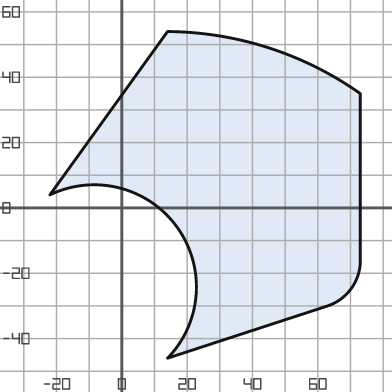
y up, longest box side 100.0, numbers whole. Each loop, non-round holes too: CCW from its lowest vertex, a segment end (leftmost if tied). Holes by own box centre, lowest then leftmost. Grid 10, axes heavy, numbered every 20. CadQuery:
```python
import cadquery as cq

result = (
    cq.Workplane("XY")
    .moveTo(14.0, -46.0)
    .lineTo(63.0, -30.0)
    .threePointArc((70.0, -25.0), (73.0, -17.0))
    .lineTo(73.0, 35.0)
    .threePointArc((45.0, 49.0), (14.0, 54.0))
    .lineTo(-22.0, 4.0)
    .threePointArc((17.0, -6.0), (14.0, -46.0))
    .close()
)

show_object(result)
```